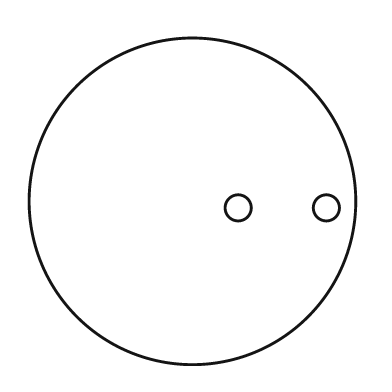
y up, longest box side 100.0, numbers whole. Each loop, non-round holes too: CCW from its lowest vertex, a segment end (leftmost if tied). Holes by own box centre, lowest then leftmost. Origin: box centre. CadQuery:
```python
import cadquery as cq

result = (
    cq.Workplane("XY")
    .moveTo(0.0, 0.0)
    .circle(50.0)
    .moveTo(14.0, -2.0)
    .circle(4.0)
    .moveTo(41.0, -2.0)
    .circle(4.0)
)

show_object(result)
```